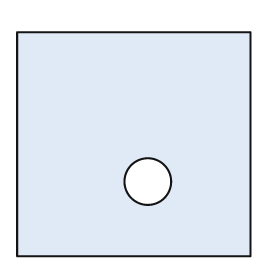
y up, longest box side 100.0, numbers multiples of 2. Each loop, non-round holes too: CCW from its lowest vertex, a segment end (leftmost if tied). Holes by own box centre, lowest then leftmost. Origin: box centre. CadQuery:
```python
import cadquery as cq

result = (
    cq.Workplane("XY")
    .moveTo(-50.0, -48.0)
    .lineTo(50.0, -48.0)
    .lineTo(50.0, 48.0)
    .lineTo(-50.0, 48.0)
    .close()
    .moveTo(6.0, -16.0)
    .circle(10.0)
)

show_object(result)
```